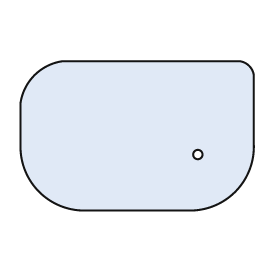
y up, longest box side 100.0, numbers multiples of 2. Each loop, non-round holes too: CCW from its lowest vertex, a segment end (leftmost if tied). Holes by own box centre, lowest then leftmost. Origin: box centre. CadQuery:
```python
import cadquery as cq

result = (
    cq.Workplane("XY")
    .moveTo(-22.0, -32.0)
    .lineTo(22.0, -32.0)
    .threePointArc((42.0, -24.0), (50.0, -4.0))
    .lineTo(50.0, 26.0)
    .threePointArc((48.0, 30.0), (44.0, 32.0))
    .lineTo(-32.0, 32.0)
    .threePointArc((-44.0, 26.0), (-50.0, 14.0))
    .lineTo(-50.0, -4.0)
    .threePointArc((-42.0, -24.0), (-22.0, -32.0))
    .close()
    .moveTo(26.0, -8.0)
    .circle(2.0)
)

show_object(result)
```